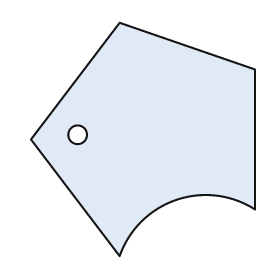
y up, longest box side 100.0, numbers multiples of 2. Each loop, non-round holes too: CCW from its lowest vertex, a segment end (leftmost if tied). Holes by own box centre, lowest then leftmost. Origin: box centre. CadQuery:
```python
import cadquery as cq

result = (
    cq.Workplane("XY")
    .moveTo(-10.0, -50.0)
    .threePointArc((14.0, -26.0), (48.0, -30.0))
    .lineTo(48.0, 30.0)
    .lineTo(-10.0, 50.0)
    .lineTo(-48.0, 0.0)
    .close()
    .moveTo(-28.0, 2.0)
    .circle(4.0)
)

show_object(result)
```